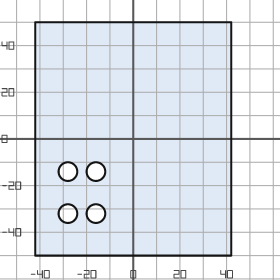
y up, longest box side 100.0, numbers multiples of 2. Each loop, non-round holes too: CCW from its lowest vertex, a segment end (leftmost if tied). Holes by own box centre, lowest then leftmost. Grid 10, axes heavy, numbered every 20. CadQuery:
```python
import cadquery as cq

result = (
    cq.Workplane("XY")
    .moveTo(-42.0, -50.0)
    .lineTo(42.0, -50.0)
    .lineTo(42.0, 50.0)
    .lineTo(-42.0, 50.0)
    .close()
    .moveTo(-28.0, -32.0)
    .circle(4.0)
    .moveTo(-16.0, -32.0)
    .circle(4.0)
    .moveTo(-28.0, -14.0)
    .circle(4.0)
    .moveTo(-16.0, -14.0)
    .circle(4.0)
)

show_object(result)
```